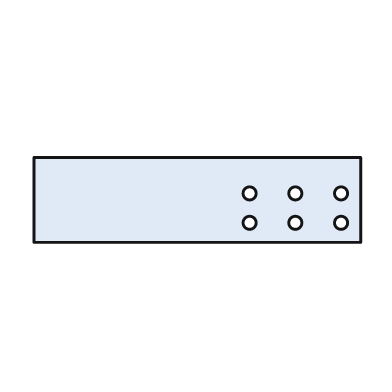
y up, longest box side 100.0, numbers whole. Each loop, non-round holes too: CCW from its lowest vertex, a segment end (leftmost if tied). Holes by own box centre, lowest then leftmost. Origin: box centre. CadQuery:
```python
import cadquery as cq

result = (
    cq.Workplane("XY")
    .moveTo(-50.0, -13.0)
    .lineTo(50.0, -13.0)
    .lineTo(50.0, 13.0)
    .lineTo(-50.0, 13.0)
    .close()
    .moveTo(16.0, -7.0)
    .circle(2.0)
    .moveTo(30.0, -7.0)
    .circle(2.0)
    .moveTo(44.0, -7.0)
    .circle(2.0)
    .moveTo(16.0, 2.0)
    .circle(2.0)
    .moveTo(30.0, 2.0)
    .circle(2.0)
    .moveTo(44.0, 2.0)
    .circle(2.0)
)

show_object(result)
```